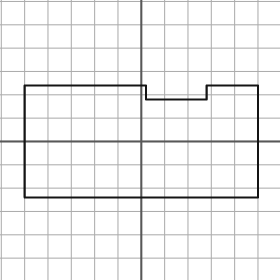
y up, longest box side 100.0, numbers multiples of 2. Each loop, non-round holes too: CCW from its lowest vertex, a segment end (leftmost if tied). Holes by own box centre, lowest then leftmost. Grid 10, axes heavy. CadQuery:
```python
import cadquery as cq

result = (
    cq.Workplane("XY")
    .moveTo(-50.0, -24.0)
    .lineTo(50.0, -24.0)
    .lineTo(50.0, 24.0)
    .lineTo(28.0, 24.0)
    .lineTo(28.0, 18.0)
    .lineTo(2.0, 18.0)
    .lineTo(2.0, 24.0)
    .lineTo(-50.0, 24.0)
    .close()
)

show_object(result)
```